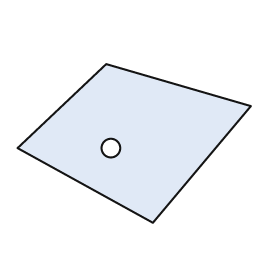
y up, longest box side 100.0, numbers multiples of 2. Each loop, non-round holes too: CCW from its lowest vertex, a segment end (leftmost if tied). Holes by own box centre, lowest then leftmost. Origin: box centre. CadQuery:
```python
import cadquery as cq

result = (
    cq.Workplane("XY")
    .moveTo(8.0, -34.0)
    .lineTo(50.0, 16.0)
    .lineTo(-12.0, 34.0)
    .lineTo(-50.0, -2.0)
    .close()
    .moveTo(-10.0, -2.0)
    .circle(4.0)
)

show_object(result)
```